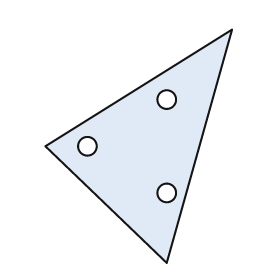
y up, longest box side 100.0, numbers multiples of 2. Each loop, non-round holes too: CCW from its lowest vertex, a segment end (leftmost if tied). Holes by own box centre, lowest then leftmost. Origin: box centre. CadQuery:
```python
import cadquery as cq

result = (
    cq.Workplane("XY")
    .moveTo(12.0, -50.0)
    .lineTo(40.0, 50.0)
    .lineTo(-40.0, 0.0)
    .close()
    .moveTo(12.0, -20.0)
    .circle(4.0)
    .moveTo(-22.0, 0.0)
    .circle(4.0)
    .moveTo(12.0, 20.0)
    .circle(4.0)
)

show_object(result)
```